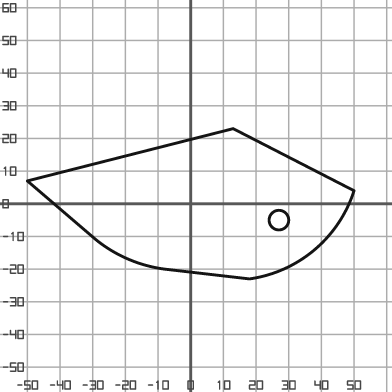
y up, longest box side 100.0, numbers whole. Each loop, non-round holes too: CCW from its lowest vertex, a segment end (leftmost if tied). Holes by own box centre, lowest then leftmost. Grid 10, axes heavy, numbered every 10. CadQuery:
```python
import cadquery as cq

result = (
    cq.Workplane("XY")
    .moveTo(18.0, -23.0)
    .threePointArc((38.0, -14.0), (50.0, 4.0))
    .lineTo(13.0, 23.0)
    .lineTo(-50.0, 7.0)
    .lineTo(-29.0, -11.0)
    .threePointArc((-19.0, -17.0), (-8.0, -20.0))
    .close()
    .moveTo(27.0, -5.0)
    .circle(3.0)
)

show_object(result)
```